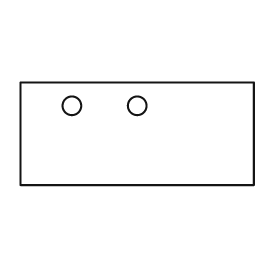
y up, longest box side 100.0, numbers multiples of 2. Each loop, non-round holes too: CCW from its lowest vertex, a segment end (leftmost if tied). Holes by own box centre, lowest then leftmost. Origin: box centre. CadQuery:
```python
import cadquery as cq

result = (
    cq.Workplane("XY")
    .moveTo(-50.0, -22.0)
    .lineTo(50.0, -22.0)
    .lineTo(50.0, 22.0)
    .lineTo(-50.0, 22.0)
    .close()
    .moveTo(-28.0, 12.0)
    .circle(4.0)
    .moveTo(0.0, 12.0)
    .circle(4.0)
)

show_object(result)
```